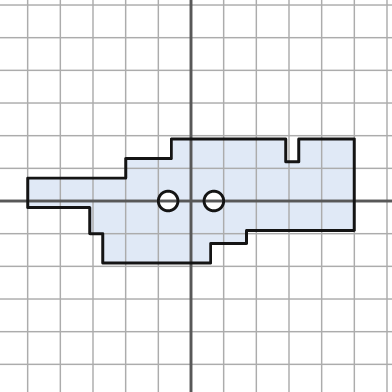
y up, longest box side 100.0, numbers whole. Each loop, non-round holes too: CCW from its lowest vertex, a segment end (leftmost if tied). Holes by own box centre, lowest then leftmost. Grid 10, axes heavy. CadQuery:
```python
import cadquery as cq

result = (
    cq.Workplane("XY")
    .moveTo(-27.0, -19.0)
    .lineTo(6.0, -19.0)
    .lineTo(6.0, -13.0)
    .lineTo(17.0, -13.0)
    .lineTo(17.0, -9.0)
    .lineTo(50.0, -9.0)
    .lineTo(50.0, 19.0)
    .lineTo(33.0, 19.0)
    .lineTo(33.0, 12.0)
    .lineTo(29.0, 12.0)
    .lineTo(29.0, 19.0)
    .lineTo(-6.0, 19.0)
    .lineTo(-6.0, 13.0)
    .lineTo(-20.0, 13.0)
    .lineTo(-20.0, 7.0)
    .lineTo(-50.0, 7.0)
    .lineTo(-50.0, -2.0)
    .lineTo(-31.0, -2.0)
    .lineTo(-31.0, -10.0)
    .lineTo(-27.0, -10.0)
    .close()
    .moveTo(-7.0, 0.0)
    .circle(3.0)
    .moveTo(7.0, 0.0)
    .circle(3.0)
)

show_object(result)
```